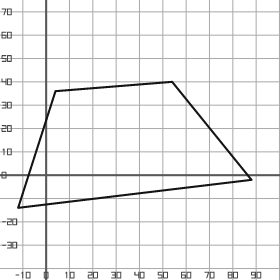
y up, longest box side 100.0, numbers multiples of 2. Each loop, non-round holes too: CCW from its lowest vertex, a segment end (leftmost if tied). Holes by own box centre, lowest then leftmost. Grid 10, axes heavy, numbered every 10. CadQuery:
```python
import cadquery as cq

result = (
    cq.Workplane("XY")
    .moveTo(-12.0, -14.0)
    .lineTo(88.0, -2.0)
    .lineTo(54.0, 40.0)
    .lineTo(4.0, 36.0)
    .close()
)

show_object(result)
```